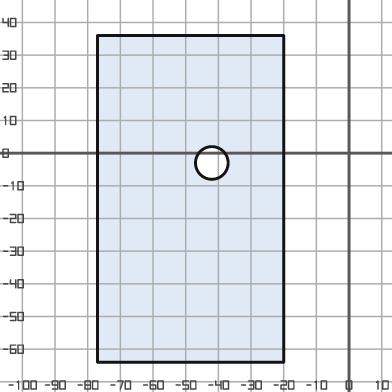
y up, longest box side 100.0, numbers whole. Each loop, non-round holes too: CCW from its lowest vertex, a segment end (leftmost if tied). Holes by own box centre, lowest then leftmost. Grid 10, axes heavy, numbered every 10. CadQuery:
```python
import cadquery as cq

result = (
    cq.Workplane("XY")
    .moveTo(-77.0, -64.0)
    .lineTo(-20.0, -64.0)
    .lineTo(-20.0, 36.0)
    .lineTo(-77.0, 36.0)
    .close()
    .moveTo(-42.0, -3.0)
    .circle(5.0)
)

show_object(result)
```